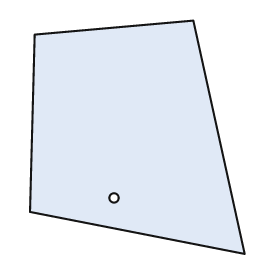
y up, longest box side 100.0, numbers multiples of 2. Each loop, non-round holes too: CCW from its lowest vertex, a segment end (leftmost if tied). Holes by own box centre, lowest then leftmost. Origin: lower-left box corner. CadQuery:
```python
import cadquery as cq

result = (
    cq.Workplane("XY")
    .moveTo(92.0, 0.0)
    .lineTo(70.0, 100.0)
    .lineTo(2.0, 94.0)
    .lineTo(0.0, 18.0)
    .close()
    .moveTo(36.0, 24.0)
    .circle(2.0)
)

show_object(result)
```